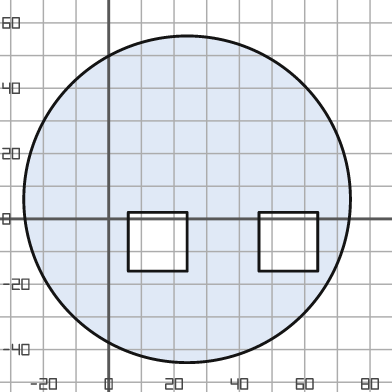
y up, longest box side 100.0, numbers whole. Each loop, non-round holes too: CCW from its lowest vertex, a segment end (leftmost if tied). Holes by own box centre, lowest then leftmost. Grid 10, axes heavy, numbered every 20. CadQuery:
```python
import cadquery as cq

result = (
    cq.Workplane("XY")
    .moveTo(24.0, 6.0)
    .circle(50.0)
    .moveTo(6.0, -16.0)
    .lineTo(24.0, -16.0)
    .lineTo(24.0, 2.0)
    .lineTo(6.0, 2.0)
    .close()
    .moveTo(46.0, -16.0)
    .lineTo(64.0, -16.0)
    .lineTo(64.0, 2.0)
    .lineTo(46.0, 2.0)
    .close()
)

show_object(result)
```